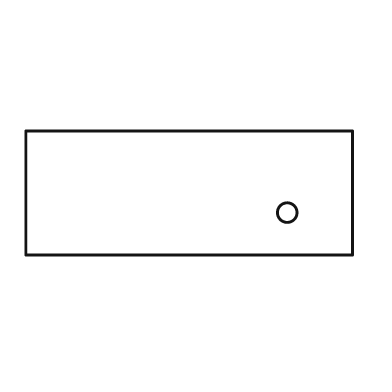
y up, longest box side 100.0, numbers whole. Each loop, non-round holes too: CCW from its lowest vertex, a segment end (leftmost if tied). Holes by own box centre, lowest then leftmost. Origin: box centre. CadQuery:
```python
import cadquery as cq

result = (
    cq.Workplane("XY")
    .moveTo(-50.0, -19.0)
    .lineTo(50.0, -19.0)
    .lineTo(50.0, 19.0)
    .lineTo(-50.0, 19.0)
    .close()
    .moveTo(30.0, -6.0)
    .circle(3.0)
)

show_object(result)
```